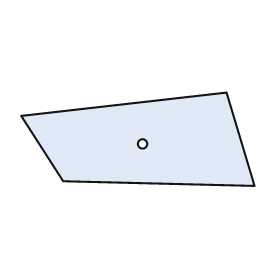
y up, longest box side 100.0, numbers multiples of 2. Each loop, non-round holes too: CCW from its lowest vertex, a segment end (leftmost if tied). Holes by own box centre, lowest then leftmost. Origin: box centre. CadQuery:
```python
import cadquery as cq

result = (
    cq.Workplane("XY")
    .moveTo(50.0, -20.0)
    .lineTo(38.0, 20.0)
    .lineTo(-50.0, 10.0)
    .lineTo(-32.0, -18.0)
    .close()
    .moveTo(2.0, -2.0)
    .circle(2.0)
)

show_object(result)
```